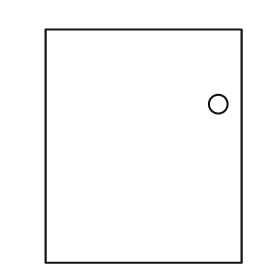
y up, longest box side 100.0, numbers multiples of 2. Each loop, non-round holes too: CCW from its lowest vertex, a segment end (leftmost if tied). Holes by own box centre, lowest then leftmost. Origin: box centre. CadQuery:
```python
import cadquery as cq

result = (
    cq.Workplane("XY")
    .moveTo(-42.0, -50.0)
    .lineTo(42.0, -50.0)
    .lineTo(42.0, 50.0)
    .lineTo(-42.0, 50.0)
    .close()
    .moveTo(32.0, 18.0)
    .circle(4.0)
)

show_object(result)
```